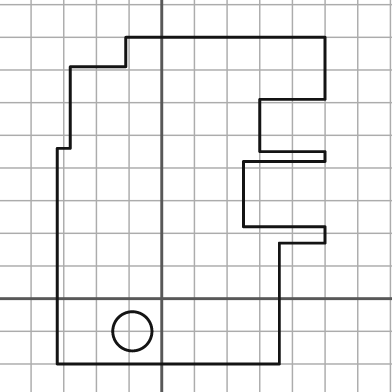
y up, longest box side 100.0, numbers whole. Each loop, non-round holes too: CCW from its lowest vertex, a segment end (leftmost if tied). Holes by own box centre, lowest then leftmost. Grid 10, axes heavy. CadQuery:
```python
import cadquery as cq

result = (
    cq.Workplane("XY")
    .moveTo(-32.0, -20.0)
    .lineTo(36.0, -20.0)
    .lineTo(36.0, 17.0)
    .lineTo(50.0, 17.0)
    .lineTo(50.0, 22.0)
    .lineTo(25.0, 22.0)
    .lineTo(25.0, 42.0)
    .lineTo(50.0, 42.0)
    .lineTo(50.0, 45.0)
    .lineTo(30.0, 45.0)
    .lineTo(30.0, 61.0)
    .lineTo(50.0, 61.0)
    .lineTo(50.0, 80.0)
    .lineTo(-11.0, 80.0)
    .lineTo(-11.0, 71.0)
    .lineTo(-28.0, 71.0)
    .lineTo(-28.0, 46.0)
    .lineTo(-32.0, 46.0)
    .close()
    .moveTo(-9.0, -10.0)
    .circle(6.0)
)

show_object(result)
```